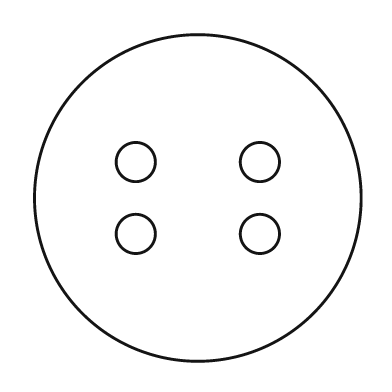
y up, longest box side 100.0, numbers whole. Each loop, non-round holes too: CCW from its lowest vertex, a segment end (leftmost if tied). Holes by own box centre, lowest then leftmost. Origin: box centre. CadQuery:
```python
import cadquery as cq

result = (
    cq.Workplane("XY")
    .moveTo(0.0, 0.0)
    .circle(50.0)
    .moveTo(-19.0, -11.0)
    .circle(6.0)
    .moveTo(19.0, -11.0)
    .circle(6.0)
    .moveTo(-19.0, 11.0)
    .circle(6.0)
    .moveTo(19.0, 11.0)
    .circle(6.0)
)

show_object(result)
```